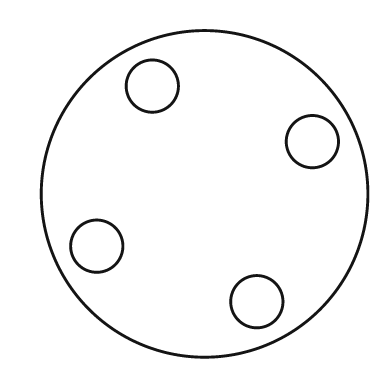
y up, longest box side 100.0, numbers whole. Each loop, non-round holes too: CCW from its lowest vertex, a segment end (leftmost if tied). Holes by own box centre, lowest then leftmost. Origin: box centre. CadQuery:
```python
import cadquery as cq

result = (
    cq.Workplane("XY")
    .moveTo(0.0, 0.0)
    .circle(50.0)
    .moveTo(16.0, -33.0)
    .circle(8.0)
    .moveTo(-33.0, -16.0)
    .circle(8.0)
    .moveTo(33.0, 16.0)
    .circle(8.0)
    .moveTo(-16.0, 33.0)
    .circle(8.0)
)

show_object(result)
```